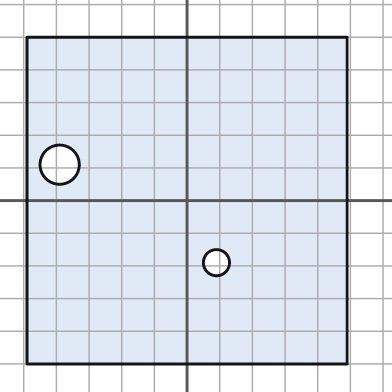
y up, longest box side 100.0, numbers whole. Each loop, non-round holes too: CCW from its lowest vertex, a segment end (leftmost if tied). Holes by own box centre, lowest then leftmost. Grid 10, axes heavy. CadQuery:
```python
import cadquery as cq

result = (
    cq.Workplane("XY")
    .moveTo(-49.0, -50.0)
    .lineTo(49.0, -50.0)
    .lineTo(49.0, 50.0)
    .lineTo(-49.0, 50.0)
    .close()
    .moveTo(9.0, -19.0)
    .circle(4.0)
    .moveTo(-39.0, 11.0)
    .circle(6.0)
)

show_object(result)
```